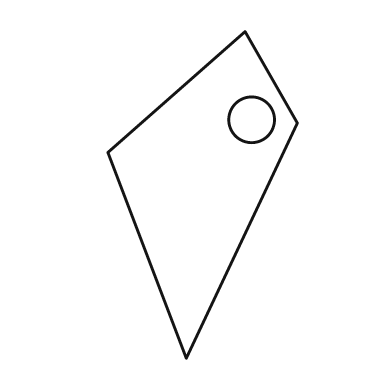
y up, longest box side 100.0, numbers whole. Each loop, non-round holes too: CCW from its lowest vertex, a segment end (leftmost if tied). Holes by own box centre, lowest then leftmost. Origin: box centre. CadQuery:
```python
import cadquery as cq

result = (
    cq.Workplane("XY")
    .moveTo(-5.0, -50.0)
    .lineTo(29.0, 22.0)
    .lineTo(13.0, 50.0)
    .lineTo(-29.0, 13.0)
    .close()
    .moveTo(15.0, 23.0)
    .circle(7.0)
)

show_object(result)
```